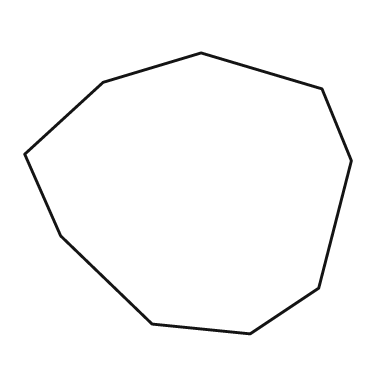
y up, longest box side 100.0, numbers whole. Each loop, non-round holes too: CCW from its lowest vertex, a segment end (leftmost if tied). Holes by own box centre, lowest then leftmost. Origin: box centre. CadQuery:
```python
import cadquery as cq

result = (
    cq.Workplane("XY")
    .moveTo(19.0, -43.0)
    .lineTo(40.0, -29.0)
    .lineTo(50.0, 10.0)
    .lineTo(41.0, 32.0)
    .lineTo(4.0, 43.0)
    .lineTo(-26.0, 34.0)
    .lineTo(-50.0, 12.0)
    .lineTo(-39.0, -13.0)
    .lineTo(-11.0, -40.0)
    .close()
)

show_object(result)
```